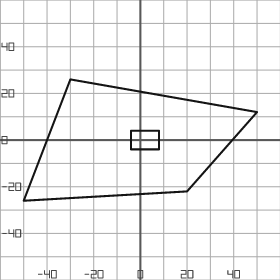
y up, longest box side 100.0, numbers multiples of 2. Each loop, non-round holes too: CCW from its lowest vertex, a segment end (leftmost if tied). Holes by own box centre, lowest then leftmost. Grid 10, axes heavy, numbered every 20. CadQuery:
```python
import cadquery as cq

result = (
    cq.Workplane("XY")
    .moveTo(-50.0, -26.0)
    .lineTo(20.0, -22.0)
    .lineTo(50.0, 12.0)
    .lineTo(-30.0, 26.0)
    .close()
    .moveTo(-4.0, -4.0)
    .lineTo(8.0, -4.0)
    .lineTo(8.0, 4.0)
    .lineTo(-4.0, 4.0)
    .close()
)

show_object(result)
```